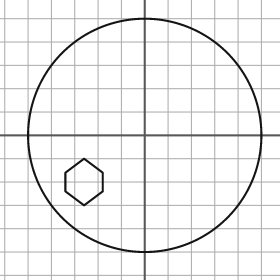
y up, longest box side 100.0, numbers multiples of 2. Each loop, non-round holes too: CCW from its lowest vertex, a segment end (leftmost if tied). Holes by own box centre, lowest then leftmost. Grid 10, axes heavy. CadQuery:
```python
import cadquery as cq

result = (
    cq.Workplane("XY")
    .moveTo(0.0, 0.0)
    .circle(50.0)
    .moveTo(-26.0, -30.0)
    .lineTo(-18.0, -24.0)
    .lineTo(-18.0, -16.0)
    .lineTo(-26.0, -10.0)
    .lineTo(-34.0, -16.0)
    .lineTo(-34.0, -24.0)
    .close()
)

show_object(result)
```